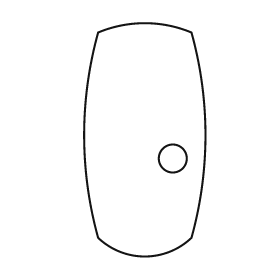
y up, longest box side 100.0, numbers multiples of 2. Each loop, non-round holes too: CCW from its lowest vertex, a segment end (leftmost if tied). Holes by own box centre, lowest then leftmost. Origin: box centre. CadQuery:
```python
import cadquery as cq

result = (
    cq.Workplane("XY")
    .moveTo(-20.0, -42.0)
    .threePointArc((0.0, -50.0), (20.0, -42.0))
    .threePointArc((26.0, 2.0), (20.0, 46.0))
    .threePointArc((0.0, 50.0), (-20.0, 46.0))
    .threePointArc((-26.0, 2.0), (-20.0, -42.0))
    .close()
    .moveTo(12.0, -8.0)
    .circle(6.0)
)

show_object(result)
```